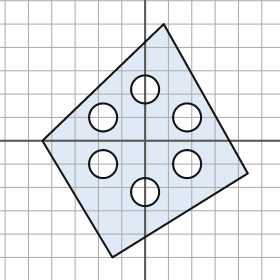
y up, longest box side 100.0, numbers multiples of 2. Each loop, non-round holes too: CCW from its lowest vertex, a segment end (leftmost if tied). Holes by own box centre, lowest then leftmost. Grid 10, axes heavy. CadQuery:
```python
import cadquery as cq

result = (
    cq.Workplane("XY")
    .moveTo(-14.0, -50.0)
    .lineTo(44.0, -14.0)
    .lineTo(8.0, 50.0)
    .lineTo(-44.0, 0.0)
    .close()
    .moveTo(0.0, -22.0)
    .circle(6.0)
    .moveTo(-18.0, -10.0)
    .circle(6.0)
    .moveTo(18.0, -10.0)
    .circle(6.0)
    .moveTo(-18.0, 10.0)
    .circle(6.0)
    .moveTo(18.0, 10.0)
    .circle(6.0)
    .moveTo(0.0, 22.0)
    .circle(6.0)
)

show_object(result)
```